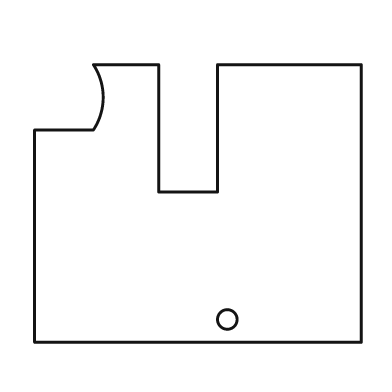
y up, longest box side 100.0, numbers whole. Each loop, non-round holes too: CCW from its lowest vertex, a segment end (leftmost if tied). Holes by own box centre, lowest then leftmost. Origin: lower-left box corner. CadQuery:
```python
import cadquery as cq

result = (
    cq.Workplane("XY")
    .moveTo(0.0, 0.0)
    .lineTo(100.0, 0.0)
    .lineTo(100.0, 85.0)
    .lineTo(56.0, 85.0)
    .lineTo(56.0, 46.0)
    .lineTo(38.0, 46.0)
    .lineTo(38.0, 85.0)
    .lineTo(18.0, 85.0)
    .threePointArc((21.0, 75.0), (18.0, 65.0))
    .lineTo(0.0, 65.0)
    .close()
    .moveTo(59.0, 7.0)
    .circle(3.0)
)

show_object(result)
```